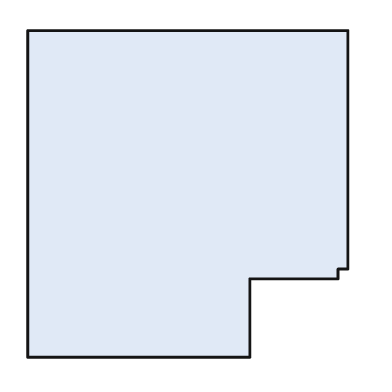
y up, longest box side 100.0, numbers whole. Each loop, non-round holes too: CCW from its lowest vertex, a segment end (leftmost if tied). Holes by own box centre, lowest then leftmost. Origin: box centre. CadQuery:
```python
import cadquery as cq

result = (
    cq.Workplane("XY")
    .moveTo(-49.0, -50.0)
    .lineTo(19.0, -50.0)
    .lineTo(19.0, -26.0)
    .lineTo(46.0, -26.0)
    .lineTo(46.0, -23.0)
    .lineTo(49.0, -23.0)
    .lineTo(49.0, 50.0)
    .lineTo(-49.0, 50.0)
    .close()
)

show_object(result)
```